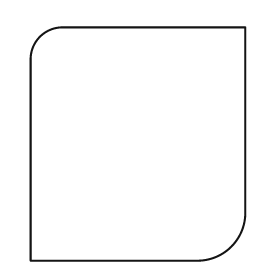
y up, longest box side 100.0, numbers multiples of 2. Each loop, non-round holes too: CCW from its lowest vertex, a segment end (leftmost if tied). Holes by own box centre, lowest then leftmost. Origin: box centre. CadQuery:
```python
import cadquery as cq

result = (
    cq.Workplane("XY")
    .moveTo(-46.0, -50.0)
    .lineTo(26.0, -50.0)
    .threePointArc((40.0, -44.0), (46.0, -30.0))
    .lineTo(46.0, 50.0)
    .lineTo(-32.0, 50.0)
    .threePointArc((-42.0, 46.0), (-46.0, 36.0))
    .close()
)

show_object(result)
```